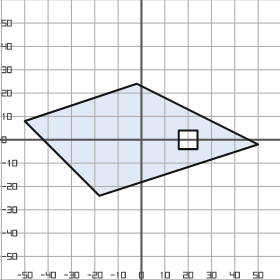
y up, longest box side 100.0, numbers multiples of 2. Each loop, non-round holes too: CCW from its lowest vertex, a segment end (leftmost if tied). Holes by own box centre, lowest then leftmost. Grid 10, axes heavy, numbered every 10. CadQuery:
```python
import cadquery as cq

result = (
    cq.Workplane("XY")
    .moveTo(-18.0, -24.0)
    .lineTo(50.0, -2.0)
    .lineTo(-2.0, 24.0)
    .lineTo(-50.0, 8.0)
    .close()
    .moveTo(16.0, -4.0)
    .lineTo(24.0, -4.0)
    .lineTo(24.0, 4.0)
    .lineTo(16.0, 4.0)
    .close()
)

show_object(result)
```